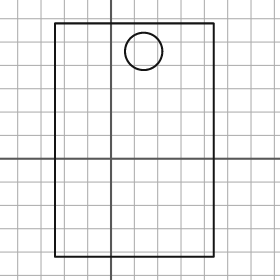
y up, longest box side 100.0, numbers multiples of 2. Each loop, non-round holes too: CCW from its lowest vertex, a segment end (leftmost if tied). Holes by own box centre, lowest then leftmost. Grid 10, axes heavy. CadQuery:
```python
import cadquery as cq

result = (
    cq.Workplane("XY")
    .moveTo(-24.0, -42.0)
    .lineTo(44.0, -42.0)
    .lineTo(44.0, 58.0)
    .lineTo(-24.0, 58.0)
    .close()
    .moveTo(14.0, 46.0)
    .circle(8.0)
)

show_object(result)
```